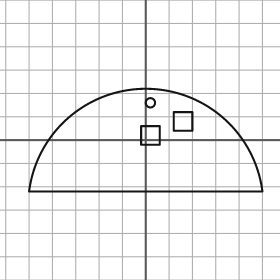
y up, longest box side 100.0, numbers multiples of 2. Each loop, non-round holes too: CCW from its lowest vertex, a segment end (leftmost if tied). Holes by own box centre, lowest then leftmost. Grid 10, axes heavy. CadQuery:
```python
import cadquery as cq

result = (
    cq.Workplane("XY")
    .moveTo(-50.0, -22.0)
    .lineTo(50.0, -22.0)
    .threePointArc((0.0, 22.0), (-50.0, -22.0))
    .close()
    .moveTo(-2.0, -2.0)
    .lineTo(6.0, -2.0)
    .lineTo(6.0, 6.0)
    .lineTo(-2.0, 6.0)
    .close()
    .moveTo(12.0, 4.0)
    .lineTo(20.0, 4.0)
    .lineTo(20.0, 12.0)
    .lineTo(12.0, 12.0)
    .close()
    .moveTo(2.0, 16.0)
    .circle(2.0)
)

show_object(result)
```